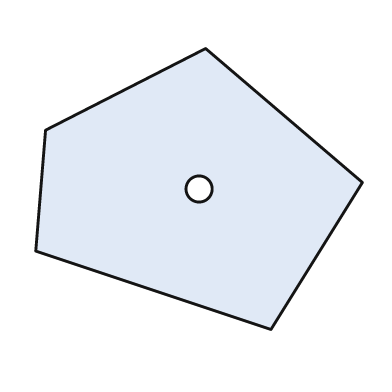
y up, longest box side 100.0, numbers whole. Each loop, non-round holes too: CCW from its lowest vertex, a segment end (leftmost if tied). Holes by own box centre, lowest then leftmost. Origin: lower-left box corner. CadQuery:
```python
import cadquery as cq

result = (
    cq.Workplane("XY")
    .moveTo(72.0, 0.0)
    .lineTo(100.0, 45.0)
    .lineTo(52.0, 86.0)
    .lineTo(3.0, 61.0)
    .lineTo(0.0, 24.0)
    .close()
    .moveTo(50.0, 43.0)
    .circle(4.0)
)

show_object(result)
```